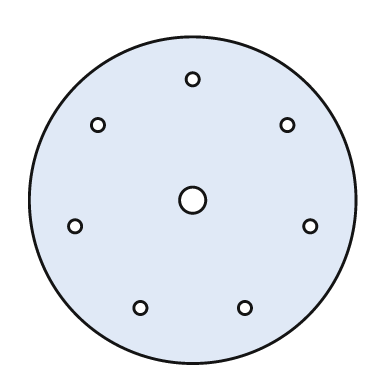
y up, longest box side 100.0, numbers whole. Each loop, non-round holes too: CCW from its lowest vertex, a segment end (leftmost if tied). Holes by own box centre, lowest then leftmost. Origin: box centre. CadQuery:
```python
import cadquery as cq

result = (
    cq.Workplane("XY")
    .moveTo(0.0, 0.0)
    .circle(50.0)
    .moveTo(-16.0, -33.0)
    .circle(2.0)
    .moveTo(16.0, -33.0)
    .circle(2.0)
    .moveTo(-36.0, -8.0)
    .circle(2.0)
    .moveTo(36.0, -8.0)
    .circle(2.0)
    .moveTo(0.0, 0.0)
    .circle(4.0)
    .moveTo(-29.0, 23.0)
    .circle(2.0)
    .moveTo(29.0, 23.0)
    .circle(2.0)
    .moveTo(0.0, 37.0)
    .circle(2.0)
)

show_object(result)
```